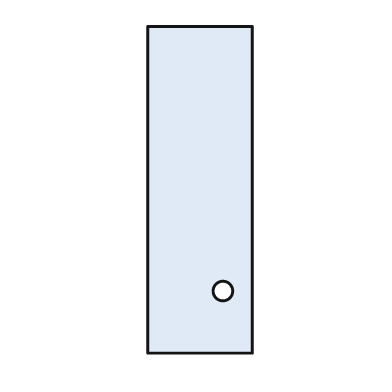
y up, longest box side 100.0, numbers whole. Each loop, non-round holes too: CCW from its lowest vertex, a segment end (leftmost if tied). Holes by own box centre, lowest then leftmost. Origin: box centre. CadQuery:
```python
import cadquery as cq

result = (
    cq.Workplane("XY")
    .moveTo(-16.0, -50.0)
    .lineTo(16.0, -50.0)
    .lineTo(16.0, 50.0)
    .lineTo(-16.0, 50.0)
    .close()
    .moveTo(7.0, -31.0)
    .circle(3.0)
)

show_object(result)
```